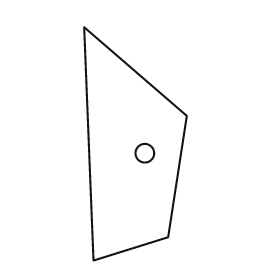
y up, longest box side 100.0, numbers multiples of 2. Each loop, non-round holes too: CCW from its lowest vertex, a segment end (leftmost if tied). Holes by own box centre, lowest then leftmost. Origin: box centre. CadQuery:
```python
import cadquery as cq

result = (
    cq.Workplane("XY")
    .moveTo(-18.0, -50.0)
    .lineTo(14.0, -40.0)
    .lineTo(22.0, 12.0)
    .lineTo(-22.0, 50.0)
    .close()
    .moveTo(4.0, -4.0)
    .circle(4.0)
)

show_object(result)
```